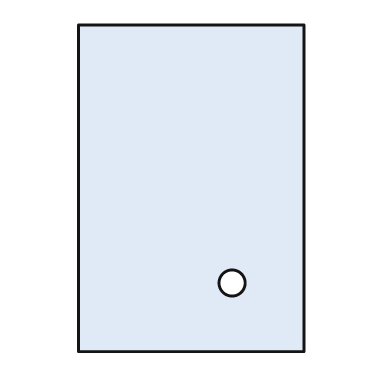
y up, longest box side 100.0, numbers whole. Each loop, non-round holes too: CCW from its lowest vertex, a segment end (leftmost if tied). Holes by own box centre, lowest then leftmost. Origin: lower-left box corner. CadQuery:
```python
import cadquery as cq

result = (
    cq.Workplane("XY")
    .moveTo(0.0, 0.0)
    .lineTo(69.0, 0.0)
    .lineTo(69.0, 100.0)
    .lineTo(0.0, 100.0)
    .close()
    .moveTo(47.0, 21.0)
    .circle(4.0)
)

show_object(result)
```